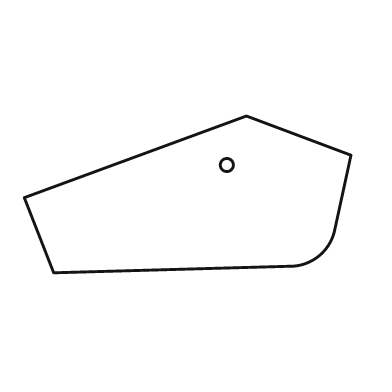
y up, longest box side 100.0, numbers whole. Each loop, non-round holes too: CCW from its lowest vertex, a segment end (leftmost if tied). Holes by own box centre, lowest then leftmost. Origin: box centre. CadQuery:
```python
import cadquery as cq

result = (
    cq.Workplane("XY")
    .moveTo(-41.0, -24.0)
    .lineTo(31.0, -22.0)
    .threePointArc((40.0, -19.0), (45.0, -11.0))
    .lineTo(50.0, 12.0)
    .lineTo(18.0, 24.0)
    .lineTo(-50.0, -1.0)
    .close()
    .moveTo(12.0, 9.0)
    .circle(2.0)
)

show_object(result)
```